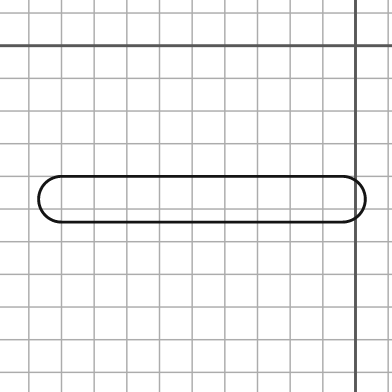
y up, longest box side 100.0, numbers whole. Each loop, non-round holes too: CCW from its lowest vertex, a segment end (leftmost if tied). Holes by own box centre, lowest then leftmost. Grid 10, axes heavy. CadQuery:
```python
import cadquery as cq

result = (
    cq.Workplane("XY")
    .moveTo(-90.0, -54.0)
    .lineTo(-4.0, -54.0)
    .threePointArc((3.0, -47.0), (-4.0, -40.0))
    .lineTo(-90.0, -40.0)
    .threePointArc((-97.0, -47.0), (-90.0, -54.0))
    .close()
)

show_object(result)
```